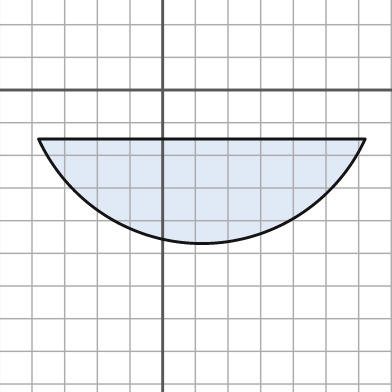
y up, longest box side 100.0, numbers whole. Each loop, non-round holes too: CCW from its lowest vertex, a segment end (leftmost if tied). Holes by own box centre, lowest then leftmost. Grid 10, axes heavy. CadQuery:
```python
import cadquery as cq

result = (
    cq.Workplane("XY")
    .moveTo(-38.0, -15.0)
    .threePointArc((12.0, -47.0), (62.0, -15.0))
    .close()
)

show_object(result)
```